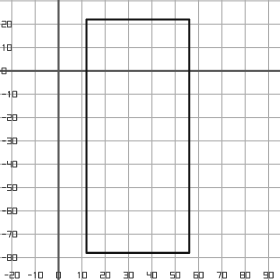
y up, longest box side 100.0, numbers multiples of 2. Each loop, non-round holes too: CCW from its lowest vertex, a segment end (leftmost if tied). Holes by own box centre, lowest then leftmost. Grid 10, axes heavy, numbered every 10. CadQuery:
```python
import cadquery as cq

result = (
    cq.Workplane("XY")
    .moveTo(12.0, -78.0)
    .lineTo(56.0, -78.0)
    .lineTo(56.0, 22.0)
    .lineTo(12.0, 22.0)
    .close()
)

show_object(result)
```